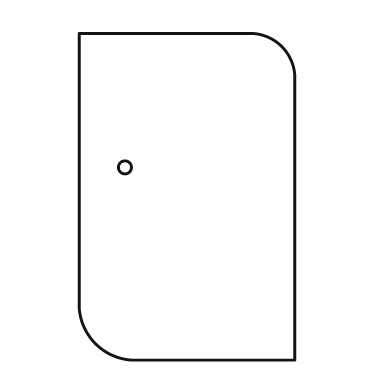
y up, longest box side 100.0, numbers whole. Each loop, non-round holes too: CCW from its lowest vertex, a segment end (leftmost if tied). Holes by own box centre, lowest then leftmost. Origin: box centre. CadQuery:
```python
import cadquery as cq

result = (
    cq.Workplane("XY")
    .moveTo(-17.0, -50.0)
    .lineTo(33.0, -50.0)
    .lineTo(33.0, 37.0)
    .threePointArc((29.0, 46.0), (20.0, 50.0))
    .lineTo(-33.0, 50.0)
    .lineTo(-33.0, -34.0)
    .threePointArc((-28.0, -45.0), (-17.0, -50.0))
    .close()
    .moveTo(-19.0, 9.0)
    .circle(2.0)
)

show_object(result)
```